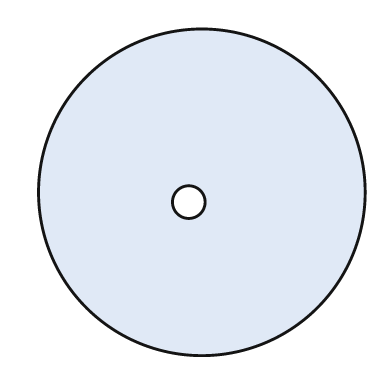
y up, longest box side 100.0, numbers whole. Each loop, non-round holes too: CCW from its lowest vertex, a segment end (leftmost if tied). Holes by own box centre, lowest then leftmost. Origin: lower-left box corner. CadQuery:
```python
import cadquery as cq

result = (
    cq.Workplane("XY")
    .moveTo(50.0, 50.0)
    .circle(50.0)
    .moveTo(46.0, 47.0)
    .circle(5.0)
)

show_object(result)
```